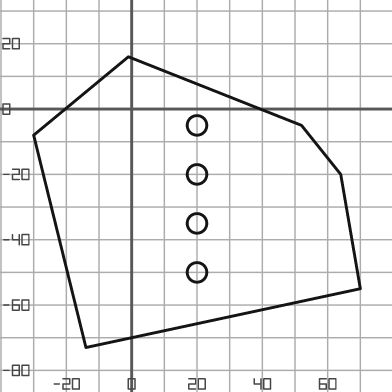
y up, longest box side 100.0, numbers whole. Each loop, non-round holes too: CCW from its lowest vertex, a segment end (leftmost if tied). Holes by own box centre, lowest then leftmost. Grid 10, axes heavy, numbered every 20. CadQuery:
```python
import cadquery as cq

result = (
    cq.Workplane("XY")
    .moveTo(-14.0, -73.0)
    .lineTo(70.0, -55.0)
    .lineTo(64.0, -20.0)
    .lineTo(52.0, -5.0)
    .lineTo(-1.0, 16.0)
    .lineTo(-30.0, -8.0)
    .close()
    .moveTo(20.0, -50.0)
    .circle(3.0)
    .moveTo(20.0, -35.0)
    .circle(3.0)
    .moveTo(20.0, -20.0)
    .circle(3.0)
    .moveTo(20.0, -5.0)
    .circle(3.0)
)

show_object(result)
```